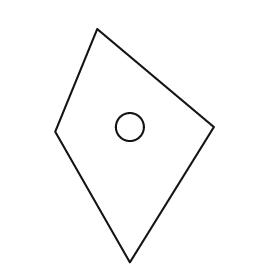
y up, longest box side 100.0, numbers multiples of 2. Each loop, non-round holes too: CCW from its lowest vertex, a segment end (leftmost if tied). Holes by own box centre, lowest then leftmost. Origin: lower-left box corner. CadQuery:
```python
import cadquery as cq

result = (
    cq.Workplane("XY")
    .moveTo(32.0, 0.0)
    .lineTo(68.0, 58.0)
    .lineTo(18.0, 100.0)
    .lineTo(0.0, 56.0)
    .close()
    .moveTo(32.0, 58.0)
    .circle(6.0)
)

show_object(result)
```